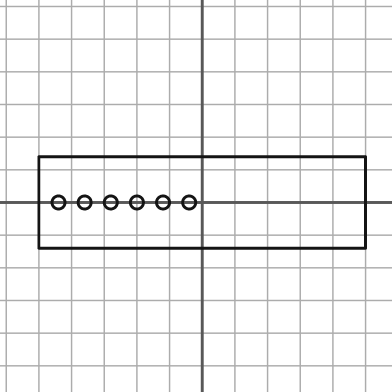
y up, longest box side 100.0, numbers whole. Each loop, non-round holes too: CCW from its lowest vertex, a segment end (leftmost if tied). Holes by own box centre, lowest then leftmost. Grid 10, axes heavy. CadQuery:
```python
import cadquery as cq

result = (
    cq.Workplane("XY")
    .moveTo(-50.0, -14.0)
    .lineTo(50.0, -14.0)
    .lineTo(50.0, 14.0)
    .lineTo(-50.0, 14.0)
    .close()
    .moveTo(-44.0, 0.0)
    .circle(2.0)
    .moveTo(-36.0, 0.0)
    .circle(2.0)
    .moveTo(-28.0, 0.0)
    .circle(2.0)
    .moveTo(-20.0, 0.0)
    .circle(2.0)
    .moveTo(-12.0, 0.0)
    .circle(2.0)
    .moveTo(-4.0, 0.0)
    .circle(2.0)
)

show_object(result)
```